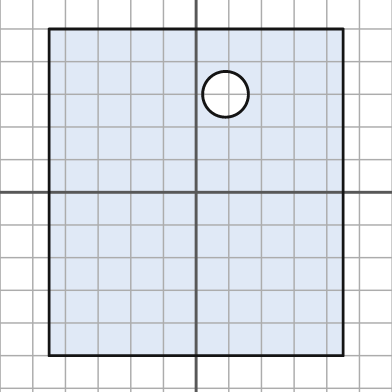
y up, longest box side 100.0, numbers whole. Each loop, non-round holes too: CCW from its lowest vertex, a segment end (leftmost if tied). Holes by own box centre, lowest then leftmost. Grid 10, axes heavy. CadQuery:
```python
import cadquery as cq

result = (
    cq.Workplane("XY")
    .moveTo(-45.0, -50.0)
    .lineTo(45.0, -50.0)
    .lineTo(45.0, 50.0)
    .lineTo(-45.0, 50.0)
    .close()
    .moveTo(9.0, 30.0)
    .circle(7.0)
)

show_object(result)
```